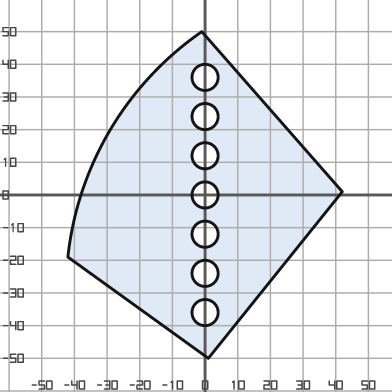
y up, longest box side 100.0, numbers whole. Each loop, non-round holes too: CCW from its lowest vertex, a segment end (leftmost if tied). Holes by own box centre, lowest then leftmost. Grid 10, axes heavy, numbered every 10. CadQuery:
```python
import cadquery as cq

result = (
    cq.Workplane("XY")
    .moveTo(1.0, -50.0)
    .lineTo(42.0, 1.0)
    .lineTo(-1.0, 50.0)
    .threePointArc((-29.0, 20.0), (-42.0, -19.0))
    .close()
    .moveTo(0.0, -36.0)
    .circle(4.0)
    .moveTo(0.0, -24.0)
    .circle(4.0)
    .moveTo(0.0, -12.0)
    .circle(4.0)
    .moveTo(0.0, 0.0)
    .circle(4.0)
    .moveTo(0.0, 12.0)
    .circle(4.0)
    .moveTo(0.0, 24.0)
    .circle(4.0)
    .moveTo(0.0, 36.0)
    .circle(4.0)
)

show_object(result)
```